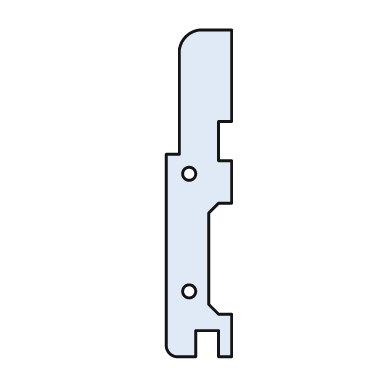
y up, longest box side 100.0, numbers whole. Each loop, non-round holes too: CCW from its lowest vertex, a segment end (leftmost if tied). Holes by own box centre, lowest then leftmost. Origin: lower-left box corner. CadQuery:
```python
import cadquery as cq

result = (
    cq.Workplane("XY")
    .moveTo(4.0, 0.0)
    .lineTo(9.0, 0.0)
    .lineTo(9.0, 8.0)
    .lineTo(16.0, 8.0)
    .lineTo(16.0, 0.0)
    .lineTo(20.0, 0.0)
    .lineTo(20.0, 13.0)
    .lineTo(16.0, 13.0)
    .lineTo(13.0, 16.0)
    .lineTo(13.0, 44.0)
    .lineTo(16.0, 47.0)
    .lineTo(20.0, 47.0)
    .lineTo(20.0, 60.0)
    .lineTo(16.0, 60.0)
    .lineTo(16.0, 72.0)
    .lineTo(20.0, 72.0)
    .lineTo(20.0, 100.0)
    .lineTo(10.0, 100.0)
    .threePointArc((6.0, 98.0), (4.0, 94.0))
    .lineTo(4.0, 62.0)
    .lineTo(0.0, 62.0)
    .lineTo(0.0, 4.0)
    .threePointArc((1.0, 1.0), (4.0, 0.0))
    .close()
    .moveTo(7.0, 20.0)
    .circle(2.0)
    .moveTo(7.0, 56.0)
    .circle(2.0)
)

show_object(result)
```